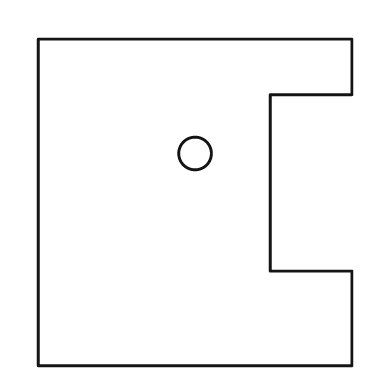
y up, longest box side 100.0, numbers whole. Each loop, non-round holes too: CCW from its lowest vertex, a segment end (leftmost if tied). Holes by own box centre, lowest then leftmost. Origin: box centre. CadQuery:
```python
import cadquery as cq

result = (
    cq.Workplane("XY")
    .moveTo(-48.0, -50.0)
    .lineTo(48.0, -50.0)
    .lineTo(48.0, -21.0)
    .lineTo(23.0, -21.0)
    .lineTo(23.0, 33.0)
    .lineTo(48.0, 33.0)
    .lineTo(48.0, 50.0)
    .lineTo(-48.0, 50.0)
    .close()
    .moveTo(0.0, 15.0)
    .circle(5.0)
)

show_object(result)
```